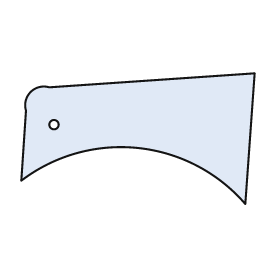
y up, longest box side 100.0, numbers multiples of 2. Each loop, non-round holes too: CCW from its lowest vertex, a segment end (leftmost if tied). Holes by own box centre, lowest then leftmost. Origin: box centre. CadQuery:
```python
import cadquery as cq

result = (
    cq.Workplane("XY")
    .moveTo(46.0, -28.0)
    .lineTo(50.0, 28.0)
    .lineTo(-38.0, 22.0)
    .threePointArc((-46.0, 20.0), (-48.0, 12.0))
    .lineTo(-50.0, -18.0)
    .threePointArc((0.0, -4.0), (46.0, -28.0))
    .close()
    .moveTo(-36.0, 6.0)
    .circle(2.0)
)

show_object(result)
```